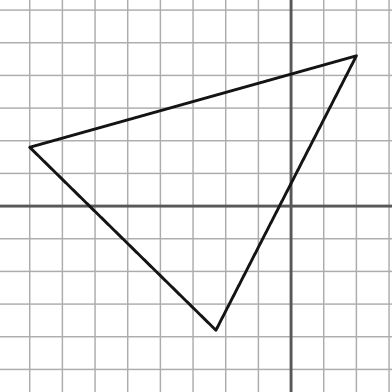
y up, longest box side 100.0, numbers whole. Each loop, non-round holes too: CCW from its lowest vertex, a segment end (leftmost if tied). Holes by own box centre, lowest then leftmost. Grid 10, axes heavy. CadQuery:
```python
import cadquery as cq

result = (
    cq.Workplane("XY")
    .moveTo(-23.0, -38.0)
    .lineTo(20.0, 46.0)
    .lineTo(-80.0, 18.0)
    .close()
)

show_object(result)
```